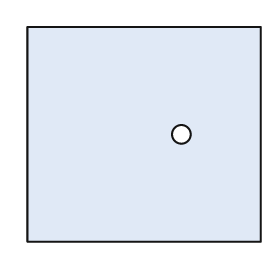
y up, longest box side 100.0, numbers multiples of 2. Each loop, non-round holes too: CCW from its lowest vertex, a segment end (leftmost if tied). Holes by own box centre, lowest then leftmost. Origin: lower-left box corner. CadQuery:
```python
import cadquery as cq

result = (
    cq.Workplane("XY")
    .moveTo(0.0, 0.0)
    .lineTo(100.0, 0.0)
    .lineTo(100.0, 92.0)
    .lineTo(0.0, 92.0)
    .close()
    .moveTo(66.0, 46.0)
    .circle(4.0)
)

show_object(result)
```